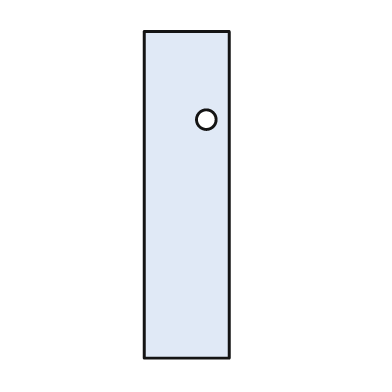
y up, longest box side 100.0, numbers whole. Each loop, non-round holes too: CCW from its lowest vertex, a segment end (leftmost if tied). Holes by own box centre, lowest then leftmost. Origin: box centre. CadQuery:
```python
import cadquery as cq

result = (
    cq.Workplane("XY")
    .moveTo(-13.0, -50.0)
    .lineTo(13.0, -50.0)
    .lineTo(13.0, 50.0)
    .lineTo(-13.0, 50.0)
    .close()
    .moveTo(6.0, 23.0)
    .circle(3.0)
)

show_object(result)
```